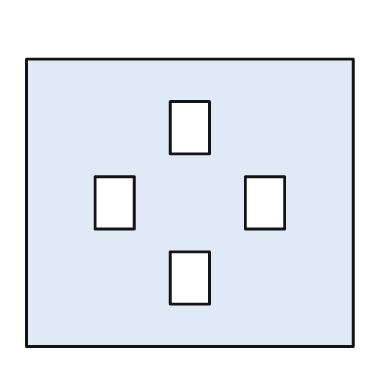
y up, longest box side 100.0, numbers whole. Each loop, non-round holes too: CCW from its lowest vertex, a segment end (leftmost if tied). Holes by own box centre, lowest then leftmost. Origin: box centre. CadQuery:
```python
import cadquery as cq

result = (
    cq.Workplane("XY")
    .moveTo(-50.0, -44.0)
    .lineTo(50.0, -44.0)
    .lineTo(50.0, 44.0)
    .lineTo(-50.0, 44.0)
    .close()
    .moveTo(-6.0, -31.0)
    .lineTo(6.0, -31.0)
    .lineTo(6.0, -15.0)
    .lineTo(-6.0, -15.0)
    .close()
    .moveTo(-29.0, -8.0)
    .lineTo(-17.0, -8.0)
    .lineTo(-17.0, 8.0)
    .lineTo(-29.0, 8.0)
    .close()
    .moveTo(17.0, -8.0)
    .lineTo(29.0, -8.0)
    .lineTo(29.0, 8.0)
    .lineTo(17.0, 8.0)
    .close()
    .moveTo(-6.0, 15.0)
    .lineTo(6.0, 15.0)
    .lineTo(6.0, 31.0)
    .lineTo(-6.0, 31.0)
    .close()
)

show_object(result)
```